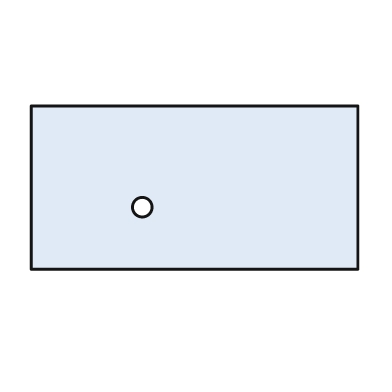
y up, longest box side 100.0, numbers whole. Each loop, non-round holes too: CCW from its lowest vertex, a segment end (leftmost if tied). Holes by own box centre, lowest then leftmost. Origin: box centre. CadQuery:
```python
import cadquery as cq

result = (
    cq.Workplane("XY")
    .moveTo(-50.0, -25.0)
    .lineTo(50.0, -25.0)
    .lineTo(50.0, 25.0)
    .lineTo(-50.0, 25.0)
    .close()
    .moveTo(-16.0, -6.0)
    .circle(3.0)
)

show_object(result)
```